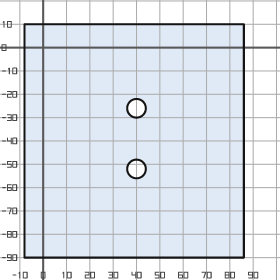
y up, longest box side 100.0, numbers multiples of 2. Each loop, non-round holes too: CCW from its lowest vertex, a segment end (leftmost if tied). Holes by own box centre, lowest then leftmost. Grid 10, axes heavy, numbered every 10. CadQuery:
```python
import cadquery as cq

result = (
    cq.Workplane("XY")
    .moveTo(-8.0, -90.0)
    .lineTo(86.0, -90.0)
    .lineTo(86.0, 10.0)
    .lineTo(-8.0, 10.0)
    .close()
    .moveTo(40.0, -52.0)
    .circle(4.0)
    .moveTo(40.0, -26.0)
    .circle(4.0)
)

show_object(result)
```